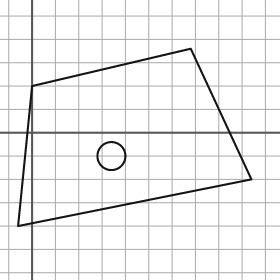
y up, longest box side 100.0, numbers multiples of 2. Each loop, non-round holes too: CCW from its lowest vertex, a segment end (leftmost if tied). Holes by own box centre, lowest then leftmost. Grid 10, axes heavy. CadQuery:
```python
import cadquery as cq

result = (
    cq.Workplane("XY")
    .moveTo(-6.0, -40.0)
    .lineTo(94.0, -20.0)
    .lineTo(68.0, 36.0)
    .lineTo(0.0, 20.0)
    .close()
    .moveTo(34.0, -10.0)
    .circle(6.0)
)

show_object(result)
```